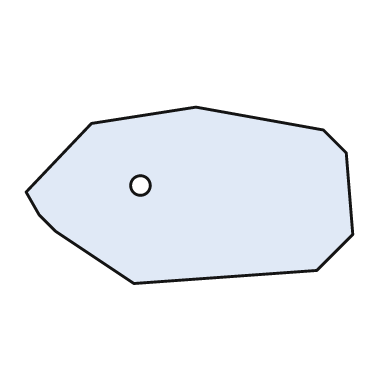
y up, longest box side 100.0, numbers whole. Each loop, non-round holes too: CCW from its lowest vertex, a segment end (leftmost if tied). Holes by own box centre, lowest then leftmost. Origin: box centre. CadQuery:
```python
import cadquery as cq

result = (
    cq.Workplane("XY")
    .moveTo(-17.0, -27.0)
    .lineTo(39.0, -23.0)
    .lineTo(50.0, -12.0)
    .lineTo(48.0, 13.0)
    .lineTo(41.0, 20.0)
    .lineTo(2.0, 27.0)
    .lineTo(-30.0, 22.0)
    .lineTo(-50.0, 1.0)
    .lineTo(-46.0, -6.0)
    .lineTo(-41.0, -11.0)
    .close()
    .moveTo(-15.0, 3.0)
    .circle(3.0)
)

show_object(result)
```